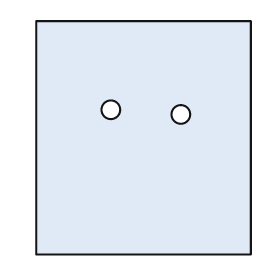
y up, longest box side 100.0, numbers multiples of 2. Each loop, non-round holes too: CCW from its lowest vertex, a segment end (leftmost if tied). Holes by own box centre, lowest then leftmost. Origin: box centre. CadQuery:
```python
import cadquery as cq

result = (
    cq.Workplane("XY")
    .moveTo(-46.0, -50.0)
    .lineTo(46.0, -50.0)
    .lineTo(46.0, 50.0)
    .lineTo(-46.0, 50.0)
    .close()
    .moveTo(16.0, 10.0)
    .circle(4.0)
    .moveTo(-14.0, 12.0)
    .circle(4.0)
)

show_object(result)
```